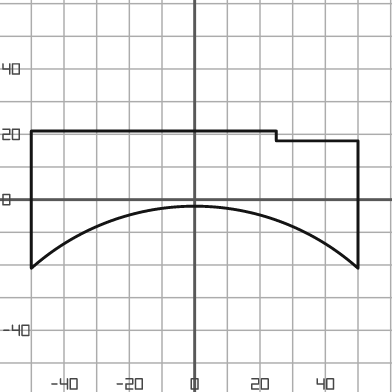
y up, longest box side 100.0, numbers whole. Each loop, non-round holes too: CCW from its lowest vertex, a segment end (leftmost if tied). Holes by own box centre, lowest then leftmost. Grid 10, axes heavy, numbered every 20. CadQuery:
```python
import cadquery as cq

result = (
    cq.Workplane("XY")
    .moveTo(-50.0, -21.0)
    .threePointArc((0.0, -2.0), (50.0, -21.0))
    .lineTo(50.0, 18.0)
    .lineTo(25.0, 18.0)
    .lineTo(25.0, 21.0)
    .lineTo(-50.0, 21.0)
    .close()
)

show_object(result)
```